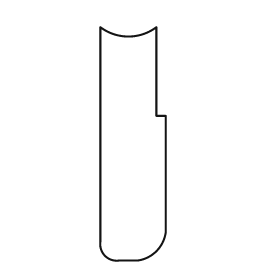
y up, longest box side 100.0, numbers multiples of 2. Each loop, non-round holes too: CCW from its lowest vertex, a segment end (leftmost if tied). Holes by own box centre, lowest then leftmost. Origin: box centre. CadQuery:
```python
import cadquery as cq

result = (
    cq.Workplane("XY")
    .moveTo(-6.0, -50.0)
    .lineTo(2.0, -50.0)
    .threePointArc((10.0, -46.0), (14.0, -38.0))
    .lineTo(14.0, 12.0)
    .lineTo(10.0, 12.0)
    .lineTo(10.0, 50.0)
    .threePointArc((-2.0, 46.0), (-14.0, 50.0))
    .lineTo(-14.0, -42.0)
    .threePointArc((-12.0, -48.0), (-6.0, -50.0))
    .close()
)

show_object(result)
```